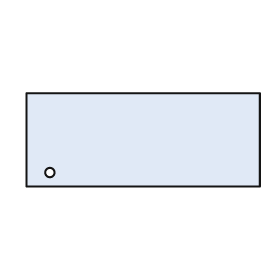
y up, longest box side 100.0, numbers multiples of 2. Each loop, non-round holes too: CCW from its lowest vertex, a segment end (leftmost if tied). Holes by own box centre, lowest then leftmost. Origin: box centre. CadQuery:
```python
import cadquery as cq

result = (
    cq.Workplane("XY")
    .moveTo(-50.0, -20.0)
    .lineTo(50.0, -20.0)
    .lineTo(50.0, 20.0)
    .lineTo(-50.0, 20.0)
    .close()
    .moveTo(-40.0, -14.0)
    .circle(2.0)
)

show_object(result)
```